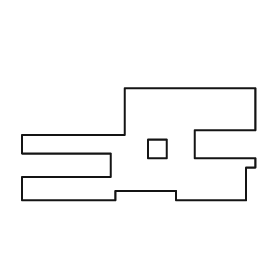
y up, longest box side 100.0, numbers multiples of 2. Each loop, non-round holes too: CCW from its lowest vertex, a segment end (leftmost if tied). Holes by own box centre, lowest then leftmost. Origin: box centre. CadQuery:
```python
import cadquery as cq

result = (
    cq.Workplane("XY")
    .moveTo(-50.0, -24.0)
    .lineTo(-10.0, -24.0)
    .lineTo(-10.0, -20.0)
    .lineTo(16.0, -20.0)
    .lineTo(16.0, -24.0)
    .lineTo(46.0, -24.0)
    .lineTo(46.0, -10.0)
    .lineTo(50.0, -10.0)
    .lineTo(50.0, -6.0)
    .lineTo(24.0, -6.0)
    .lineTo(24.0, 6.0)
    .lineTo(50.0, 6.0)
    .lineTo(50.0, 24.0)
    .lineTo(-6.0, 24.0)
    .lineTo(-6.0, 4.0)
    .lineTo(-50.0, 4.0)
    .lineTo(-50.0, -4.0)
    .lineTo(-12.0, -4.0)
    .lineTo(-12.0, -14.0)
    .lineTo(-50.0, -14.0)
    .close()
    .moveTo(4.0, -6.0)
    .lineTo(12.0, -6.0)
    .lineTo(12.0, 2.0)
    .lineTo(4.0, 2.0)
    .close()
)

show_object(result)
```